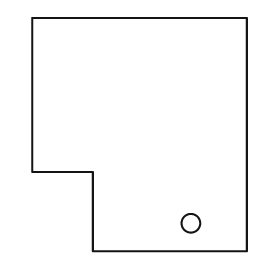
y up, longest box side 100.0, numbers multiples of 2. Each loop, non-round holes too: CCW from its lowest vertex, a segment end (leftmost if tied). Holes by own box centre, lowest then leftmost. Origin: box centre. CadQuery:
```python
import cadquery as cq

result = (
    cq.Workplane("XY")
    .moveTo(-20.0, -50.0)
    .lineTo(46.0, -50.0)
    .lineTo(46.0, 50.0)
    .lineTo(-46.0, 50.0)
    .lineTo(-46.0, -16.0)
    .lineTo(-20.0, -16.0)
    .close()
    .moveTo(22.0, -38.0)
    .circle(4.0)
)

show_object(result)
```